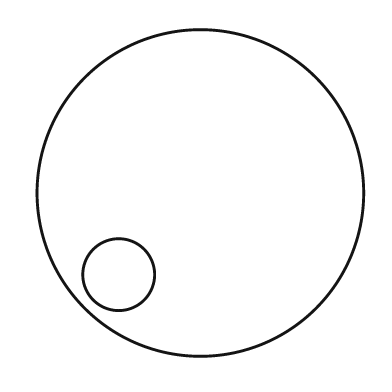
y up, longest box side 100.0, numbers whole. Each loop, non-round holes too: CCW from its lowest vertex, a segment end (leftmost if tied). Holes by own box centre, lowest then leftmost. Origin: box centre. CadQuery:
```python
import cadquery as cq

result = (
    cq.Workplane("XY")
    .moveTo(0.0, 0.0)
    .circle(50.0)
    .moveTo(-25.0, -25.0)
    .circle(11.0)
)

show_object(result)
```